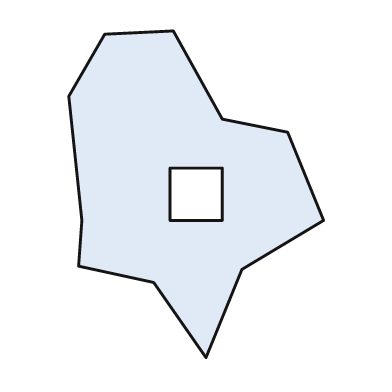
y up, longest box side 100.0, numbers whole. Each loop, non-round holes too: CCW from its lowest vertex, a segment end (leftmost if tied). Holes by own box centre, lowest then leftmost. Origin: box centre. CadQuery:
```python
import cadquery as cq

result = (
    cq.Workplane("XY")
    .moveTo(3.0, -50.0)
    .lineTo(14.0, -23.0)
    .lineTo(39.0, -8.0)
    .lineTo(28.0, 19.0)
    .lineTo(8.0, 23.0)
    .lineTo(-7.0, 50.0)
    .lineTo(-28.0, 49.0)
    .lineTo(-39.0, 30.0)
    .lineTo(-35.0, -8.0)
    .lineTo(-36.0, -22.0)
    .lineTo(-13.0, -27.0)
    .close()
    .moveTo(-8.0, -8.0)
    .lineTo(8.0, -8.0)
    .lineTo(8.0, 8.0)
    .lineTo(-8.0, 8.0)
    .close()
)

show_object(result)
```